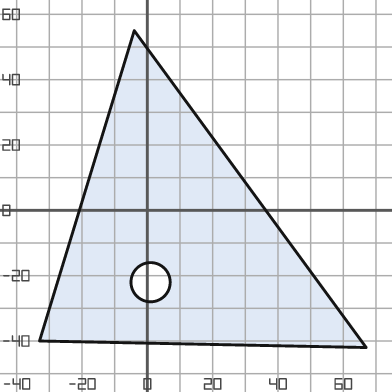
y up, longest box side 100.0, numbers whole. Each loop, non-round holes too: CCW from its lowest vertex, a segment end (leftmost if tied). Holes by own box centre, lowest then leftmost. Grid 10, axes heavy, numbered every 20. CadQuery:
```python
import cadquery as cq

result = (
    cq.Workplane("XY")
    .moveTo(67.0, -42.0)
    .lineTo(-4.0, 55.0)
    .lineTo(-33.0, -40.0)
    .close()
    .moveTo(1.0, -22.0)
    .circle(6.0)
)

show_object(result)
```